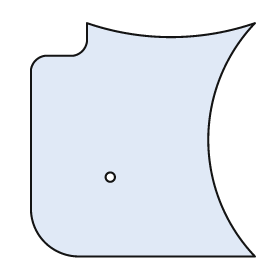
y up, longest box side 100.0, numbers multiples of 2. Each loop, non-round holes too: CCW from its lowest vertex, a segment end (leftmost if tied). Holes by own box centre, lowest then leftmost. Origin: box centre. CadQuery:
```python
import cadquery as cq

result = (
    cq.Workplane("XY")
    .moveTo(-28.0, -50.0)
    .lineTo(48.0, -50.0)
    .threePointArc((28.0, 0.0), (48.0, 50.0))
    .threePointArc((12.0, 44.0), (-24.0, 50.0))
    .lineTo(-24.0, 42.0)
    .threePointArc((-26.0, 38.0), (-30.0, 36.0))
    .lineTo(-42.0, 36.0)
    .threePointArc((-46.0, 34.0), (-48.0, 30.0))
    .lineTo(-48.0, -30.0)
    .threePointArc((-42.0, -44.0), (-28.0, -50.0))
    .close()
    .moveTo(-14.0, -16.0)
    .circle(2.0)
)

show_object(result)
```